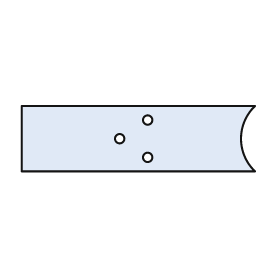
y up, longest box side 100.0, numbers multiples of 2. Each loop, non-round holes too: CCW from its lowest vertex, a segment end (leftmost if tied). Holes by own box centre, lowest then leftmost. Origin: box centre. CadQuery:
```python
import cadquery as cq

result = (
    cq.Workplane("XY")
    .moveTo(-50.0, -14.0)
    .lineTo(50.0, -14.0)
    .threePointArc((44.0, 0.0), (50.0, 14.0))
    .lineTo(-50.0, 14.0)
    .close()
    .moveTo(4.0, -8.0)
    .circle(2.0)
    .moveTo(-8.0, 0.0)
    .circle(2.0)
    .moveTo(4.0, 8.0)
    .circle(2.0)
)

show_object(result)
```